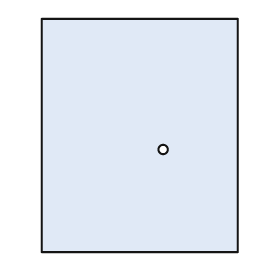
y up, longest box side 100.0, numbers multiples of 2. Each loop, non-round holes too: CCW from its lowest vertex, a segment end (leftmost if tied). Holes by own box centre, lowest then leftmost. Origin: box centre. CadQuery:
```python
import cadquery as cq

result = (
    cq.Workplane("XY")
    .moveTo(-42.0, -50.0)
    .lineTo(42.0, -50.0)
    .lineTo(42.0, 50.0)
    .lineTo(-42.0, 50.0)
    .close()
    .moveTo(10.0, -6.0)
    .circle(2.0)
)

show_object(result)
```